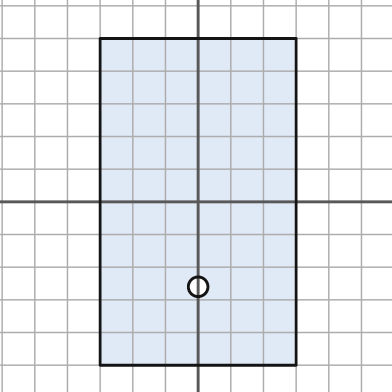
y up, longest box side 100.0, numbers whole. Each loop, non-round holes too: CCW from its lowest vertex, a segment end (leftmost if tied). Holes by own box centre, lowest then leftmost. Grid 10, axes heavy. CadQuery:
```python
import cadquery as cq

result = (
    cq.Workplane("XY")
    .moveTo(-30.0, -50.0)
    .lineTo(30.0, -50.0)
    .lineTo(30.0, 50.0)
    .lineTo(-30.0, 50.0)
    .close()
    .moveTo(0.0, -26.0)
    .circle(3.0)
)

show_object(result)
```